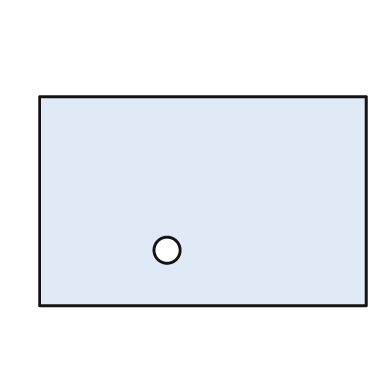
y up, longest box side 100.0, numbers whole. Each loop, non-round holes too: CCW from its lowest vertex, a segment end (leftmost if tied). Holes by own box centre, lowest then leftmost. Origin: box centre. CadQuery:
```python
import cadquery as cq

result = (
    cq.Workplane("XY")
    .moveTo(-50.0, -32.0)
    .lineTo(50.0, -32.0)
    .lineTo(50.0, 32.0)
    .lineTo(-50.0, 32.0)
    .close()
    .moveTo(-11.0, -15.0)
    .circle(4.0)
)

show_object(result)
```